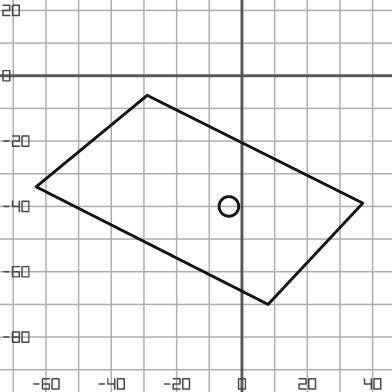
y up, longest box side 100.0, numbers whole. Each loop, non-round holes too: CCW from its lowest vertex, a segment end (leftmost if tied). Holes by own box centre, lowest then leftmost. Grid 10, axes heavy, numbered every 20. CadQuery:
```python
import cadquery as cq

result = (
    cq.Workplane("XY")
    .moveTo(8.0, -70.0)
    .lineTo(37.0, -39.0)
    .lineTo(-29.0, -6.0)
    .lineTo(-63.0, -34.0)
    .close()
    .moveTo(-4.0, -40.0)
    .circle(3.0)
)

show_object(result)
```